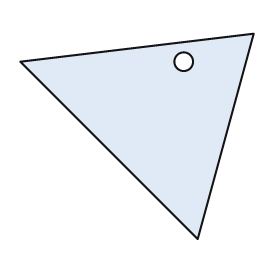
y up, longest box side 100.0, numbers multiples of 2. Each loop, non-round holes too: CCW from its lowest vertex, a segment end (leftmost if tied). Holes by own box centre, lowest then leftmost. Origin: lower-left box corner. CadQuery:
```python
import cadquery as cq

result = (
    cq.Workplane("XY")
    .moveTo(76.0, 0.0)
    .lineTo(100.0, 88.0)
    .lineTo(0.0, 76.0)
    .close()
    .moveTo(70.0, 76.0)
    .circle(4.0)
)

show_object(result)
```